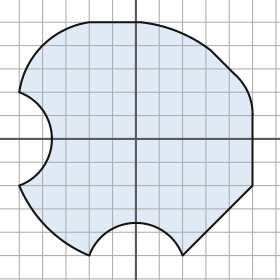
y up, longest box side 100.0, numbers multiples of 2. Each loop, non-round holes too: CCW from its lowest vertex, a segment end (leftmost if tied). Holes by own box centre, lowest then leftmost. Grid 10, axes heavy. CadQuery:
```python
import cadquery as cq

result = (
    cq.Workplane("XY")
    .moveTo(-20.0, -50.0)
    .threePointArc((0.0, -36.0), (20.0, -50.0))
    .lineTo(50.0, -20.0)
    .lineTo(50.0, 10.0)
    .threePointArc((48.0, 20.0), (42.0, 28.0))
    .lineTo(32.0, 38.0)
    .threePointArc((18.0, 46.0), (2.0, 50.0))
    .lineTo(-20.0, 50.0)
    .threePointArc((-40.0, 40.0), (-50.0, 20.0))
    .threePointArc((-36.0, 0.0), (-50.0, -20.0))
    .threePointArc((-38.0, -38.0), (-20.0, -50.0))
    .close()
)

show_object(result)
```